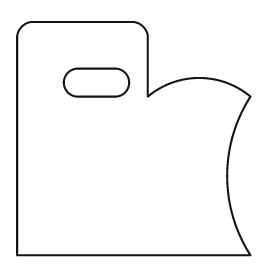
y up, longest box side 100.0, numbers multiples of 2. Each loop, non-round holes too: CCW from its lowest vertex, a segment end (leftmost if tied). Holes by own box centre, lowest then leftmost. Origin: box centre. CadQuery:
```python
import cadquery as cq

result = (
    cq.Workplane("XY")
    .moveTo(-50.0, -50.0)
    .lineTo(50.0, -50.0)
    .threePointArc((40.0, -16.0), (50.0, 18.0))
    .threePointArc((28.0, 26.0), (6.0, 18.0))
    .lineTo(6.0, 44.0)
    .threePointArc((4.0, 48.0), (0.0, 50.0))
    .lineTo(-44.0, 50.0)
    .threePointArc((-48.0, 48.0), (-50.0, 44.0))
    .close()
    .moveTo(-24.0, 18.0)
    .lineTo(-8.0, 18.0)
    .threePointArc((-2.0, 24.0), (-8.0, 30.0))
    .lineTo(-24.0, 30.0)
    .threePointArc((-30.0, 24.0), (-24.0, 18.0))
    .close()
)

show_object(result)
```